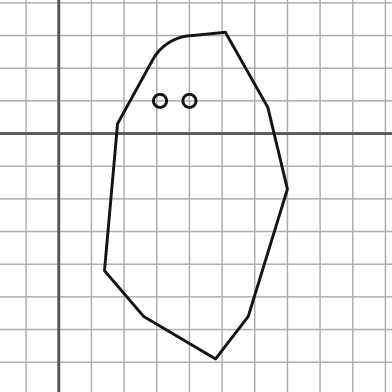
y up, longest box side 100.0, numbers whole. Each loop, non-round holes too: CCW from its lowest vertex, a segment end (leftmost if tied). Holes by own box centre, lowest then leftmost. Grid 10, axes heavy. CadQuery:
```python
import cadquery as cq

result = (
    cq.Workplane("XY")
    .moveTo(48.0, -69.0)
    .lineTo(58.0, -56.0)
    .lineTo(70.0, -17.0)
    .lineTo(64.0, 8.0)
    .lineTo(51.0, 31.0)
    .lineTo(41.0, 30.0)
    .threePointArc((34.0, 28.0), (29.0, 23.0))
    .lineTo(18.0, 3.0)
    .lineTo(14.0, -42.0)
    .lineTo(26.0, -56.0)
    .close()
    .moveTo(31.0, 10.0)
    .circle(2.0)
    .moveTo(40.0, 10.0)
    .circle(2.0)
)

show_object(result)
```